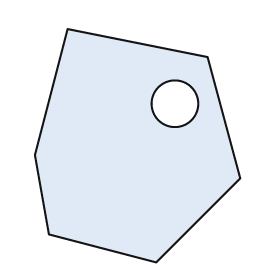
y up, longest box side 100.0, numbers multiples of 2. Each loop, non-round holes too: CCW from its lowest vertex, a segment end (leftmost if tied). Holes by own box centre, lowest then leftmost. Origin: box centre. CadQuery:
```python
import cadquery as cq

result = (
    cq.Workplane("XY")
    .moveTo(8.0, -50.0)
    .lineTo(44.0, -14.0)
    .lineTo(30.0, 38.0)
    .lineTo(-30.0, 50.0)
    .lineTo(-44.0, -4.0)
    .lineTo(-38.0, -38.0)
    .close()
    .moveTo(16.0, 18.0)
    .circle(10.0)
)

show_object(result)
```